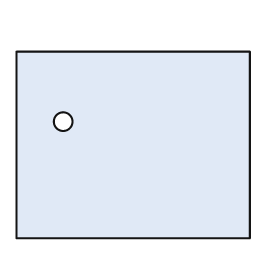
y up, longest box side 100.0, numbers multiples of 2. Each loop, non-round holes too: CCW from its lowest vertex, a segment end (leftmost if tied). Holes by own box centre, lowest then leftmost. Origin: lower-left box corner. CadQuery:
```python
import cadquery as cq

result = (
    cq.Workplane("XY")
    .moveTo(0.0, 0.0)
    .lineTo(100.0, 0.0)
    .lineTo(100.0, 80.0)
    .lineTo(0.0, 80.0)
    .close()
    .moveTo(20.0, 50.0)
    .circle(4.0)
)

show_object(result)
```